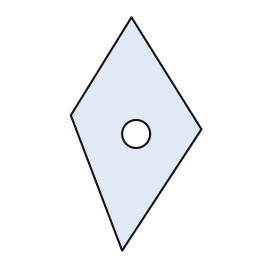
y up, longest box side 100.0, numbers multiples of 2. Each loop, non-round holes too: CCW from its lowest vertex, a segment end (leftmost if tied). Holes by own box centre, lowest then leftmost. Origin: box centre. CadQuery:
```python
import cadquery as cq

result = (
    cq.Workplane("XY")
    .moveTo(-6.0, -50.0)
    .lineTo(28.0, 2.0)
    .lineTo(-2.0, 50.0)
    .lineTo(-28.0, 8.0)
    .close()
    .moveTo(0.0, 0.0)
    .circle(6.0)
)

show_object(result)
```